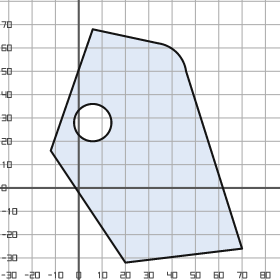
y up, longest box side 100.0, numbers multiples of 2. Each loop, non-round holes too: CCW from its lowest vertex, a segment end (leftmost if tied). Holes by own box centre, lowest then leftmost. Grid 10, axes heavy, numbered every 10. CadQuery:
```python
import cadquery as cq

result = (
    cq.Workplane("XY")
    .moveTo(20.0, -32.0)
    .lineTo(70.0, -26.0)
    .lineTo(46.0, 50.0)
    .threePointArc((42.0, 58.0), (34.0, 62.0))
    .lineTo(6.0, 68.0)
    .lineTo(-12.0, 16.0)
    .close()
    .moveTo(6.0, 28.0)
    .circle(8.0)
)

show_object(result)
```